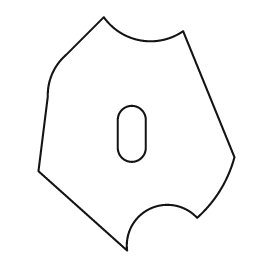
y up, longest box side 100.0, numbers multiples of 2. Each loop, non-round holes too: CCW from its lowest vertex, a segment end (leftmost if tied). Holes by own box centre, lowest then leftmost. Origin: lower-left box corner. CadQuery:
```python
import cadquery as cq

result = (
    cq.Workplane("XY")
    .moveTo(38.0, 0.0)
    .threePointArc((48.0, 18.0), (68.0, 14.0))
    .threePointArc((78.0, 26.0), (84.0, 40.0))
    .lineTo(62.0, 94.0)
    .threePointArc((44.0, 90.0), (28.0, 100.0))
    .lineTo(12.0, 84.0)
    .threePointArc((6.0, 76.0), (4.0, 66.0))
    .lineTo(0.0, 34.0)
    .close()
    .moveTo(34.0, 44.0)
    .threePointArc((40.0, 38.0), (46.0, 44.0))
    .lineTo(46.0, 56.0)
    .threePointArc((40.0, 62.0), (34.0, 56.0))
    .close()
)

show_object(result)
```